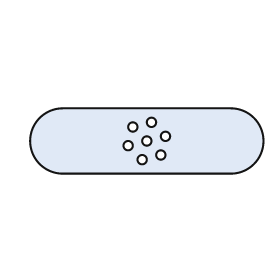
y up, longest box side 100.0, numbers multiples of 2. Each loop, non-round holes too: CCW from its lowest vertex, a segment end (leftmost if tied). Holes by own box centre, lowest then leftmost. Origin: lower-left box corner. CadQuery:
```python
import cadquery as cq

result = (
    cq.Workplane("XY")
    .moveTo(14.0, 0.0)
    .lineTo(86.0, 0.0)
    .threePointArc((100.0, 14.0), (86.0, 28.0))
    .lineTo(14.0, 28.0)
    .threePointArc((0.0, 14.0), (14.0, 0.0))
    .close()
    .moveTo(48.0, 6.0)
    .circle(2.0)
    .moveTo(56.0, 8.0)
    .circle(2.0)
    .moveTo(42.0, 12.0)
    .circle(2.0)
    .moveTo(50.0, 14.0)
    .circle(2.0)
    .moveTo(58.0, 16.0)
    .circle(2.0)
    .moveTo(44.0, 20.0)
    .circle(2.0)
    .moveTo(52.0, 22.0)
    .circle(2.0)
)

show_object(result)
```